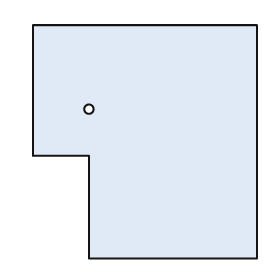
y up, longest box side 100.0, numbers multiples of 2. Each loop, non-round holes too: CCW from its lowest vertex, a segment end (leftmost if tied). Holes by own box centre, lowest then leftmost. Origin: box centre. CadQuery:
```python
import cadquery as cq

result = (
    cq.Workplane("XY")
    .moveTo(-24.0, -50.0)
    .lineTo(48.0, -50.0)
    .lineTo(48.0, 50.0)
    .lineTo(-48.0, 50.0)
    .lineTo(-48.0, -6.0)
    .lineTo(-24.0, -6.0)
    .close()
    .moveTo(-24.0, 14.0)
    .circle(2.0)
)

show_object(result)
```